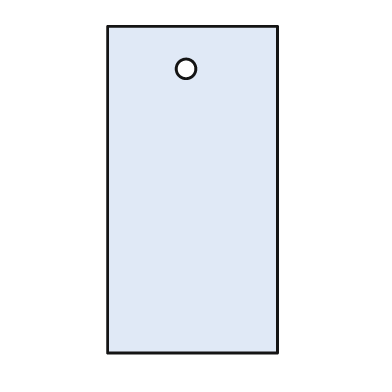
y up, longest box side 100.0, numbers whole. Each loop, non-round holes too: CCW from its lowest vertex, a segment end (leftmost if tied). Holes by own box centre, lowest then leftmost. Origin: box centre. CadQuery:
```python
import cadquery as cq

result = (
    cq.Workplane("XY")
    .moveTo(-26.0, -50.0)
    .lineTo(26.0, -50.0)
    .lineTo(26.0, 50.0)
    .lineTo(-26.0, 50.0)
    .close()
    .moveTo(-2.0, 37.0)
    .circle(3.0)
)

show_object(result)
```